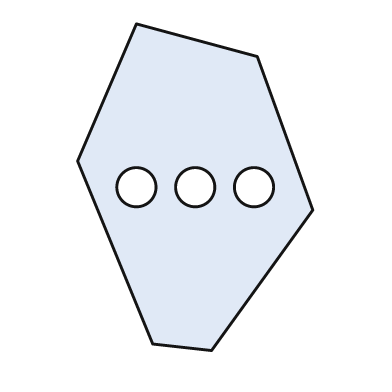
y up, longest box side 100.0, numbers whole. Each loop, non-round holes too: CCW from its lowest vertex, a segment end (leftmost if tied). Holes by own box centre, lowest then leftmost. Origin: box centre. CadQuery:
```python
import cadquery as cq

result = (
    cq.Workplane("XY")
    .moveTo(5.0, -50.0)
    .lineTo(36.0, -7.0)
    .lineTo(19.0, 40.0)
    .lineTo(-18.0, 50.0)
    .lineTo(-36.0, 8.0)
    .lineTo(-13.0, -48.0)
    .close()
    .moveTo(-18.0, 0.0)
    .circle(6.0)
    .moveTo(0.0, 0.0)
    .circle(6.0)
    .moveTo(18.0, 0.0)
    .circle(6.0)
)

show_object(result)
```